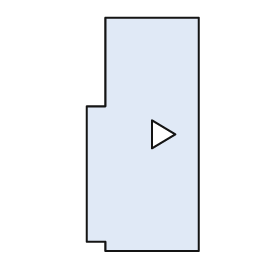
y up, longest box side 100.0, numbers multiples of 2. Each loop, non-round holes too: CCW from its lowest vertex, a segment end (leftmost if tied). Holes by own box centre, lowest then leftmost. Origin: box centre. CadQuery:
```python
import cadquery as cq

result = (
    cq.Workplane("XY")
    .moveTo(-16.0, -50.0)
    .lineTo(24.0, -50.0)
    .lineTo(24.0, 50.0)
    .lineTo(-16.0, 50.0)
    .lineTo(-16.0, 12.0)
    .lineTo(-24.0, 12.0)
    .lineTo(-24.0, -46.0)
    .lineTo(-16.0, -46.0)
    .close()
    .moveTo(4.0, -6.0)
    .lineTo(14.0, 0.0)
    .lineTo(4.0, 6.0)
    .close()
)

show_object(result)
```